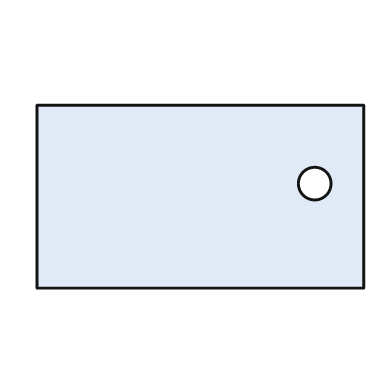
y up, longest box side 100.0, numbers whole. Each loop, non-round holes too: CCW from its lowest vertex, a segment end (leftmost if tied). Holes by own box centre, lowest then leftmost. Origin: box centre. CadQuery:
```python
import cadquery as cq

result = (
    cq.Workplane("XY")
    .moveTo(-50.0, -28.0)
    .lineTo(50.0, -28.0)
    .lineTo(50.0, 28.0)
    .lineTo(-50.0, 28.0)
    .close()
    .moveTo(35.0, 4.0)
    .circle(5.0)
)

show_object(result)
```